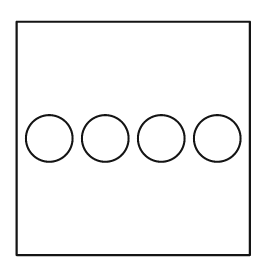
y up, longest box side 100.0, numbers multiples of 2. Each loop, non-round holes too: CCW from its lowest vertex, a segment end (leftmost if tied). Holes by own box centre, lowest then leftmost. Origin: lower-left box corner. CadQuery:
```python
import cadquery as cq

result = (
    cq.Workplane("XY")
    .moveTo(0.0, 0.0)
    .lineTo(100.0, 0.0)
    .lineTo(100.0, 100.0)
    .lineTo(0.0, 100.0)
    .close()
    .moveTo(14.0, 50.0)
    .circle(10.0)
    .moveTo(38.0, 50.0)
    .circle(10.0)
    .moveTo(62.0, 50.0)
    .circle(10.0)
    .moveTo(86.0, 50.0)
    .circle(10.0)
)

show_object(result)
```